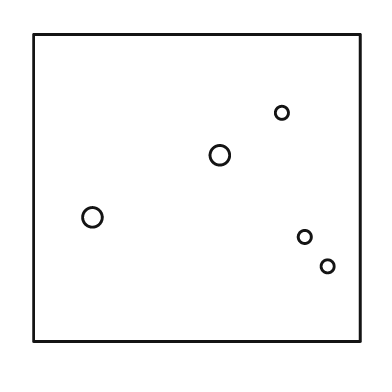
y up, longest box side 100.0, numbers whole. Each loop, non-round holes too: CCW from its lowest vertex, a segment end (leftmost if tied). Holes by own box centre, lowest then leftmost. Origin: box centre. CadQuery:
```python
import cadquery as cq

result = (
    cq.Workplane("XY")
    .moveTo(-50.0, -47.0)
    .lineTo(50.0, -47.0)
    .lineTo(50.0, 47.0)
    .lineTo(-50.0, 47.0)
    .close()
    .moveTo(40.0, -24.0)
    .circle(2.0)
    .moveTo(33.0, -15.0)
    .circle(2.0)
    .moveTo(-32.0, -9.0)
    .circle(3.0)
    .moveTo(7.0, 10.0)
    .circle(3.0)
    .moveTo(26.0, 23.0)
    .circle(2.0)
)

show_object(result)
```